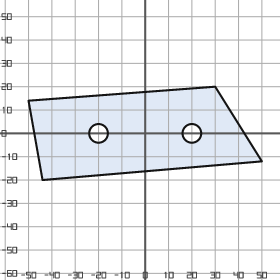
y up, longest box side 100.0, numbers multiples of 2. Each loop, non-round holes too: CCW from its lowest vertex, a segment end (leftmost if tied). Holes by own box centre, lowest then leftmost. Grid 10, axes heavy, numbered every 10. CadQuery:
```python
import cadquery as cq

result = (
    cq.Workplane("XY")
    .moveTo(-44.0, -20.0)
    .lineTo(50.0, -12.0)
    .lineTo(30.0, 20.0)
    .lineTo(-50.0, 14.0)
    .close()
    .moveTo(-20.0, 0.0)
    .circle(4.0)
    .moveTo(20.0, 0.0)
    .circle(4.0)
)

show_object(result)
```